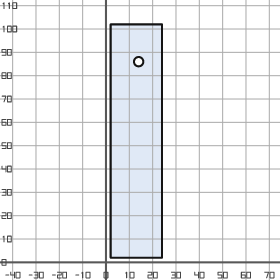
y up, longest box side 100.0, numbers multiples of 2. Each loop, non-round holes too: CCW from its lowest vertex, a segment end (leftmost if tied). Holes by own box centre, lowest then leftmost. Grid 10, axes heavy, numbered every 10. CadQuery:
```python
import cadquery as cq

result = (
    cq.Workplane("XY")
    .moveTo(2.0, 2.0)
    .lineTo(24.0, 2.0)
    .lineTo(24.0, 102.0)
    .lineTo(2.0, 102.0)
    .close()
    .moveTo(14.0, 86.0)
    .circle(2.0)
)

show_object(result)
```